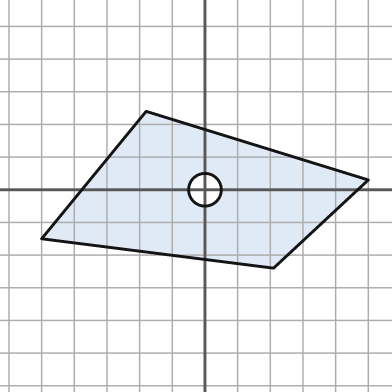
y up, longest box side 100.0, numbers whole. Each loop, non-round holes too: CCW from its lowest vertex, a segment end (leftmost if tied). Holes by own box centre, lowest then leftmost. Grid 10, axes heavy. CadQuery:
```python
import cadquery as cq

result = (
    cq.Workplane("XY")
    .moveTo(21.0, -24.0)
    .lineTo(50.0, 3.0)
    .lineTo(-18.0, 24.0)
    .lineTo(-50.0, -15.0)
    .close()
    .moveTo(0.0, 0.0)
    .circle(5.0)
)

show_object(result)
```